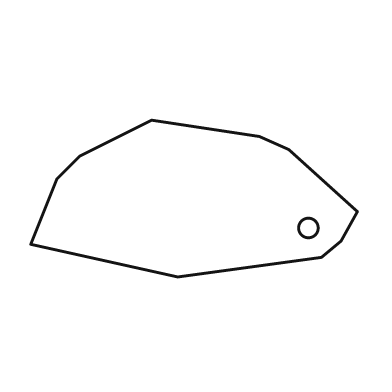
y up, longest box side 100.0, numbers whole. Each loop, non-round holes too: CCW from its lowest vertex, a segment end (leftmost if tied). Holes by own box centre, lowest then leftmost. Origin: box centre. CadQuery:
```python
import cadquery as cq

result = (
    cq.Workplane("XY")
    .moveTo(-5.0, -24.0)
    .lineTo(39.0, -18.0)
    .lineTo(45.0, -13.0)
    .lineTo(50.0, -4.0)
    .lineTo(29.0, 15.0)
    .lineTo(20.0, 19.0)
    .lineTo(-13.0, 24.0)
    .lineTo(-35.0, 13.0)
    .lineTo(-42.0, 6.0)
    .lineTo(-50.0, -14.0)
    .close()
    .moveTo(35.0, -9.0)
    .circle(3.0)
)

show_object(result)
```